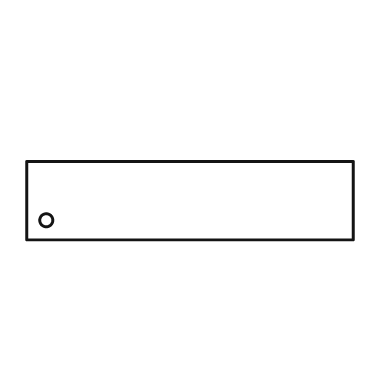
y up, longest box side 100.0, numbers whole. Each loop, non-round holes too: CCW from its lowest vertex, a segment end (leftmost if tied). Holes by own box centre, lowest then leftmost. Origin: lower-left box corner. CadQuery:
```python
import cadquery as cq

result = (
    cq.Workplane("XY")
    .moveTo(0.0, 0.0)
    .lineTo(100.0, 0.0)
    .lineTo(100.0, 24.0)
    .lineTo(0.0, 24.0)
    .close()
    .moveTo(6.0, 6.0)
    .circle(2.0)
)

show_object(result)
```